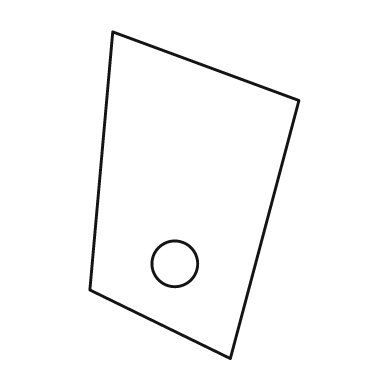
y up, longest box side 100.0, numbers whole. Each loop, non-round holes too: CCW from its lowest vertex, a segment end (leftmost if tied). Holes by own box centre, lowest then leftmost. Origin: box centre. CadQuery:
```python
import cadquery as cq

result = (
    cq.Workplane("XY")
    .moveTo(11.0, -50.0)
    .lineTo(32.0, 29.0)
    .lineTo(-25.0, 50.0)
    .lineTo(-32.0, -29.0)
    .close()
    .moveTo(-6.0, -21.0)
    .circle(7.0)
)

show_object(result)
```